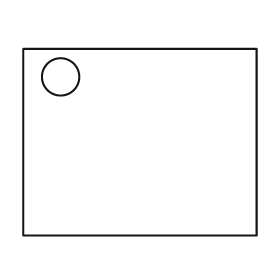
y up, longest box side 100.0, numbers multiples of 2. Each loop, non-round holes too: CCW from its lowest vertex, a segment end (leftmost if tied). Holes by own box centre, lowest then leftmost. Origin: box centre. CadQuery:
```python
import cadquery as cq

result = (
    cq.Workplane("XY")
    .moveTo(-50.0, -40.0)
    .lineTo(50.0, -40.0)
    .lineTo(50.0, 40.0)
    .lineTo(-50.0, 40.0)
    .close()
    .moveTo(-34.0, 28.0)
    .circle(8.0)
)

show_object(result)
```